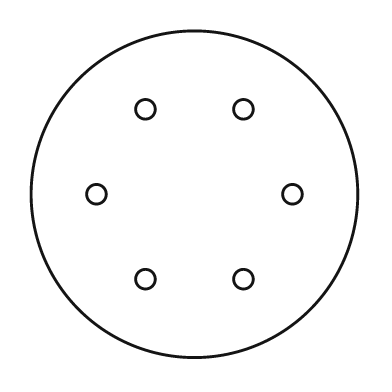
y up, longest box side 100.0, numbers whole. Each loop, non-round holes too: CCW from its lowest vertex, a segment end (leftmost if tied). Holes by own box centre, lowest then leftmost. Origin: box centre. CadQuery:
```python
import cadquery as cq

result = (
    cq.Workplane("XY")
    .moveTo(0.0, 0.0)
    .circle(50.0)
    .moveTo(-15.0, -26.0)
    .circle(3.0)
    .moveTo(15.0, -26.0)
    .circle(3.0)
    .moveTo(-30.0, 0.0)
    .circle(3.0)
    .moveTo(30.0, 0.0)
    .circle(3.0)
    .moveTo(-15.0, 26.0)
    .circle(3.0)
    .moveTo(15.0, 26.0)
    .circle(3.0)
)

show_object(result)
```